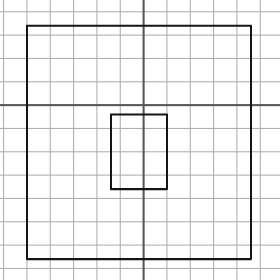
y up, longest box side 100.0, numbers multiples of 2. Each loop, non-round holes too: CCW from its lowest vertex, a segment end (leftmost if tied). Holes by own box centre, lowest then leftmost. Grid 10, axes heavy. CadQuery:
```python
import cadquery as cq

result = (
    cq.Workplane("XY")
    .moveTo(-50.0, -66.0)
    .lineTo(46.0, -66.0)
    .lineTo(46.0, 34.0)
    .lineTo(-50.0, 34.0)
    .close()
    .moveTo(-14.0, -36.0)
    .lineTo(10.0, -36.0)
    .lineTo(10.0, -4.0)
    .lineTo(-14.0, -4.0)
    .close()
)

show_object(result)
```